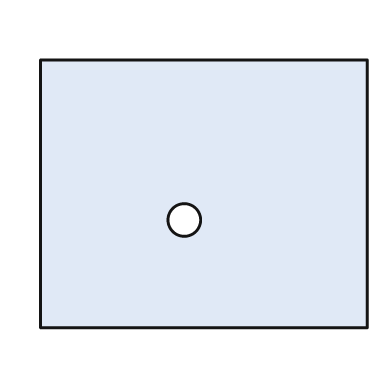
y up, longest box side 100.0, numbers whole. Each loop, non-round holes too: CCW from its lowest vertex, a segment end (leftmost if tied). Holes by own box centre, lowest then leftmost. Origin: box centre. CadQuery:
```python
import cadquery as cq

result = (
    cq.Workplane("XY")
    .moveTo(-50.0, -41.0)
    .lineTo(50.0, -41.0)
    .lineTo(50.0, 41.0)
    .lineTo(-50.0, 41.0)
    .close()
    .moveTo(-6.0, -8.0)
    .circle(5.0)
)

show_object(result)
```